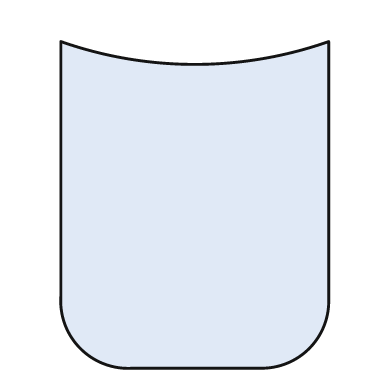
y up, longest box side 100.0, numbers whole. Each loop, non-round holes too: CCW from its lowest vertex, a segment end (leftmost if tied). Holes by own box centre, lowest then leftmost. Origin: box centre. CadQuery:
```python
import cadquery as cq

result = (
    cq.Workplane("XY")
    .moveTo(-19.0, -50.0)
    .lineTo(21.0, -50.0)
    .threePointArc((35.0, -44.0), (41.0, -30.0))
    .lineTo(41.0, 50.0)
    .threePointArc((0.0, 43.0), (-41.0, 50.0))
    .lineTo(-41.0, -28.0)
    .threePointArc((-35.0, -44.0), (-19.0, -50.0))
    .close()
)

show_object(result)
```